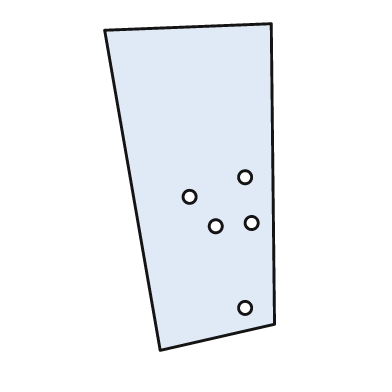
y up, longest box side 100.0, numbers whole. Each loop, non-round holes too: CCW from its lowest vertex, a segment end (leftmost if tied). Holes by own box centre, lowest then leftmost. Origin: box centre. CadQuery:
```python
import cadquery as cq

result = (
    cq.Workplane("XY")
    .moveTo(-9.0, -50.0)
    .lineTo(26.0, -42.0)
    .lineTo(25.0, 50.0)
    .lineTo(-26.0, 48.0)
    .close()
    .moveTo(17.0, -37.0)
    .circle(2.0)
    .moveTo(8.0, -12.0)
    .circle(2.0)
    .moveTo(19.0, -11.0)
    .circle(2.0)
    .moveTo(0.0, -3.0)
    .circle(2.0)
    .moveTo(17.0, 3.0)
    .circle(2.0)
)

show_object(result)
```